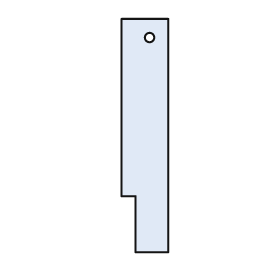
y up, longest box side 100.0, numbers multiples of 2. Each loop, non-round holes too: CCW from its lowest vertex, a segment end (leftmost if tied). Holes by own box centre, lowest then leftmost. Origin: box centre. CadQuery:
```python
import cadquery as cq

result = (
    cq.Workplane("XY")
    .moveTo(-4.0, -50.0)
    .lineTo(10.0, -50.0)
    .lineTo(10.0, 50.0)
    .lineTo(-10.0, 50.0)
    .lineTo(-10.0, -26.0)
    .lineTo(-4.0, -26.0)
    .close()
    .moveTo(2.0, 42.0)
    .circle(2.0)
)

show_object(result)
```